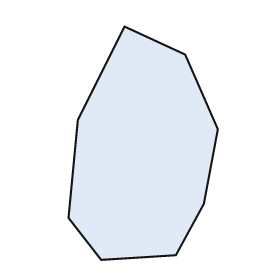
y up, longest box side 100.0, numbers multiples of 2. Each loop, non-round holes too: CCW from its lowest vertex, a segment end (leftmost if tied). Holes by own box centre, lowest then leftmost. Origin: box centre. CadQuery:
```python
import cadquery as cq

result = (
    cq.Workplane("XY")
    .moveTo(-18.0, -50.0)
    .lineTo(14.0, -48.0)
    .lineTo(26.0, -26.0)
    .lineTo(32.0, 6.0)
    .lineTo(18.0, 38.0)
    .lineTo(-8.0, 50.0)
    .lineTo(-28.0, 10.0)
    .lineTo(-32.0, -32.0)
    .close()
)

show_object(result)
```